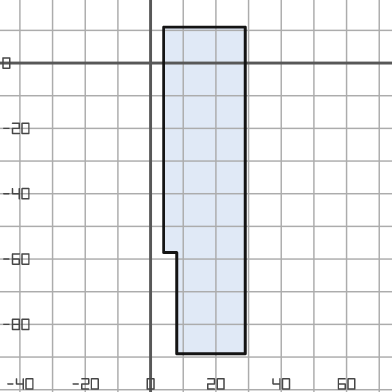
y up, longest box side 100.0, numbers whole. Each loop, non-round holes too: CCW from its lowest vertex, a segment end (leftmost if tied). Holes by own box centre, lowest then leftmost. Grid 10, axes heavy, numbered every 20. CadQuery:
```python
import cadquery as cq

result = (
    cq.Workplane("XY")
    .moveTo(8.0, -89.0)
    .lineTo(29.0, -89.0)
    .lineTo(29.0, 11.0)
    .lineTo(4.0, 11.0)
    .lineTo(4.0, -58.0)
    .lineTo(8.0, -58.0)
    .close()
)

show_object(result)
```